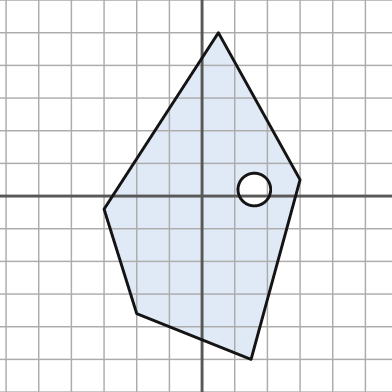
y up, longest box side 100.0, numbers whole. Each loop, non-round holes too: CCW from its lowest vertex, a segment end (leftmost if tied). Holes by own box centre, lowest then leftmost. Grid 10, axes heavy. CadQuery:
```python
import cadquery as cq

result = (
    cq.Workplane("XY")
    .moveTo(15.0, -50.0)
    .lineTo(30.0, 5.0)
    .lineTo(5.0, 50.0)
    .lineTo(-30.0, -4.0)
    .lineTo(-20.0, -36.0)
    .close()
    .moveTo(16.0, 2.0)
    .circle(5.0)
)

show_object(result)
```